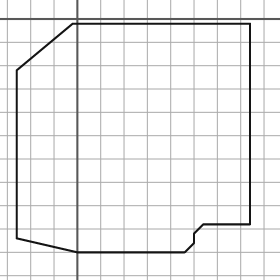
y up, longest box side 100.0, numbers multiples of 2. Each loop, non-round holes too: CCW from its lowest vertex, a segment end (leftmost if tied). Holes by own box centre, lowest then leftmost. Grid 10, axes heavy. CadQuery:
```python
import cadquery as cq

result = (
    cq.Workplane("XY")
    .moveTo(0.0, -100.0)
    .lineTo(46.0, -100.0)
    .lineTo(50.0, -96.0)
    .lineTo(50.0, -92.0)
    .lineTo(54.0, -88.0)
    .lineTo(74.0, -88.0)
    .lineTo(74.0, -2.0)
    .lineTo(-2.0, -2.0)
    .lineTo(-26.0, -22.0)
    .lineTo(-26.0, -94.0)
    .close()
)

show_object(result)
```